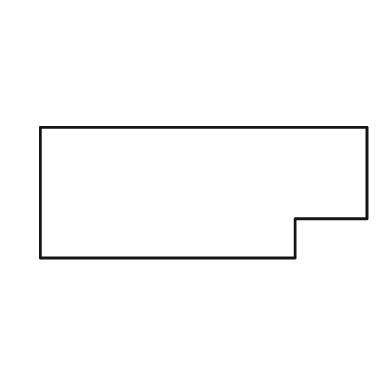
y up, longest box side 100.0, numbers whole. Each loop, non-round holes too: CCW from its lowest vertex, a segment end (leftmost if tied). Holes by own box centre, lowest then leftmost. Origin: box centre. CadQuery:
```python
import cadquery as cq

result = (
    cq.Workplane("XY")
    .moveTo(-50.0, -20.0)
    .lineTo(28.0, -20.0)
    .lineTo(28.0, -8.0)
    .lineTo(50.0, -8.0)
    .lineTo(50.0, 20.0)
    .lineTo(-50.0, 20.0)
    .close()
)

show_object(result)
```